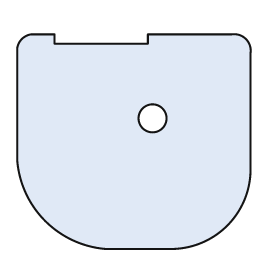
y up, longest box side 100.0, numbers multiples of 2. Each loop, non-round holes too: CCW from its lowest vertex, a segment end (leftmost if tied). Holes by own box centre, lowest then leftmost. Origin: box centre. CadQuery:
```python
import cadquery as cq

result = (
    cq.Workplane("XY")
    .moveTo(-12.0, -46.0)
    .lineTo(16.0, -46.0)
    .threePointArc((40.0, -36.0), (50.0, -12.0))
    .lineTo(50.0, 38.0)
    .threePointArc((48.0, 44.0), (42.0, 46.0))
    .lineTo(6.0, 46.0)
    .lineTo(6.0, 42.0)
    .lineTo(-34.0, 42.0)
    .lineTo(-34.0, 46.0)
    .lineTo(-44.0, 46.0)
    .threePointArc((-48.0, 44.0), (-50.0, 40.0))
    .lineTo(-50.0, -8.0)
    .threePointArc((-38.0, -34.0), (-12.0, -46.0))
    .close()
    .moveTo(8.0, 10.0)
    .circle(6.0)
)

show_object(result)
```